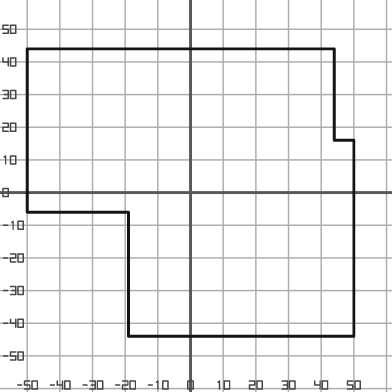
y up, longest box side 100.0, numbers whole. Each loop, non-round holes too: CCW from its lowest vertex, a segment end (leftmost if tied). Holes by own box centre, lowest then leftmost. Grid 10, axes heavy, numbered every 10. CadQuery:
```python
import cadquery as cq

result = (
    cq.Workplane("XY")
    .moveTo(-19.0, -44.0)
    .lineTo(50.0, -44.0)
    .lineTo(50.0, 16.0)
    .lineTo(44.0, 16.0)
    .lineTo(44.0, 44.0)
    .lineTo(-50.0, 44.0)
    .lineTo(-50.0, -6.0)
    .lineTo(-19.0, -6.0)
    .close()
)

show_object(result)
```